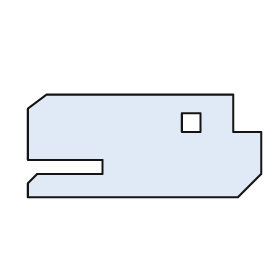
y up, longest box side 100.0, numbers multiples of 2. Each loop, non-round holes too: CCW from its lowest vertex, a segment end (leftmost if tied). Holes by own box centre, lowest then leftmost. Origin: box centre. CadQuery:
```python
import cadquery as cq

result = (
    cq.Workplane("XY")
    .moveTo(-50.0, -22.0)
    .lineTo(40.0, -22.0)
    .lineTo(50.0, -12.0)
    .lineTo(50.0, 6.0)
    .lineTo(38.0, 6.0)
    .lineTo(38.0, 22.0)
    .lineTo(-42.0, 22.0)
    .lineTo(-50.0, 16.0)
    .lineTo(-50.0, -6.0)
    .lineTo(-18.0, -6.0)
    .lineTo(-18.0, -12.0)
    .lineTo(-46.0, -12.0)
    .lineTo(-50.0, -16.0)
    .close()
    .moveTo(16.0, 6.0)
    .lineTo(24.0, 6.0)
    .lineTo(24.0, 14.0)
    .lineTo(16.0, 14.0)
    .close()
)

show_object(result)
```